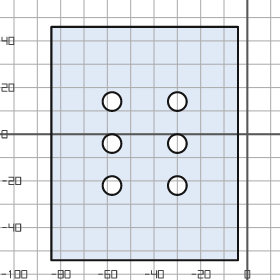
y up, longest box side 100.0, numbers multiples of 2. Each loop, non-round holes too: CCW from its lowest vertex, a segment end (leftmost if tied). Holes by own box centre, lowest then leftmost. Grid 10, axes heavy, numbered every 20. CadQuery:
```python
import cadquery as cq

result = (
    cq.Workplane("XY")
    .moveTo(-84.0, -54.0)
    .lineTo(-4.0, -54.0)
    .lineTo(-4.0, 46.0)
    .lineTo(-84.0, 46.0)
    .close()
    .moveTo(-58.0, -22.0)
    .circle(4.0)
    .moveTo(-30.0, -22.0)
    .circle(4.0)
    .moveTo(-58.0, -4.0)
    .circle(4.0)
    .moveTo(-30.0, -4.0)
    .circle(4.0)
    .moveTo(-58.0, 14.0)
    .circle(4.0)
    .moveTo(-30.0, 14.0)
    .circle(4.0)
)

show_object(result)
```